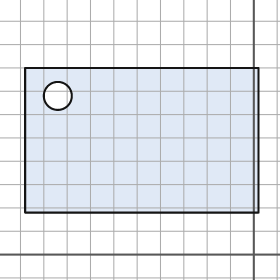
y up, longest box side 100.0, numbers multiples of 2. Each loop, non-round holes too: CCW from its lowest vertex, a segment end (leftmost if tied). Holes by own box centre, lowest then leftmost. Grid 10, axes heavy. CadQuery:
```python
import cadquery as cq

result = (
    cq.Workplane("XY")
    .moveTo(-98.0, 18.0)
    .lineTo(2.0, 18.0)
    .lineTo(2.0, 80.0)
    .lineTo(-98.0, 80.0)
    .close()
    .moveTo(-84.0, 68.0)
    .circle(6.0)
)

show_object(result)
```